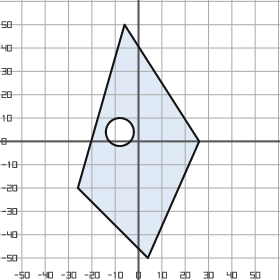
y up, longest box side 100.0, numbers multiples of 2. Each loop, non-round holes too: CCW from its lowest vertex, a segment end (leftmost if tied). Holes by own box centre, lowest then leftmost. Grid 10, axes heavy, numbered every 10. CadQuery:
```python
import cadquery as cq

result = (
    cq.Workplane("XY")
    .moveTo(4.0, -50.0)
    .lineTo(26.0, 0.0)
    .lineTo(-6.0, 50.0)
    .lineTo(-26.0, -20.0)
    .close()
    .moveTo(-8.0, 4.0)
    .circle(6.0)
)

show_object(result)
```